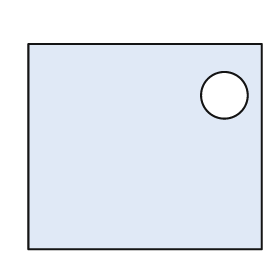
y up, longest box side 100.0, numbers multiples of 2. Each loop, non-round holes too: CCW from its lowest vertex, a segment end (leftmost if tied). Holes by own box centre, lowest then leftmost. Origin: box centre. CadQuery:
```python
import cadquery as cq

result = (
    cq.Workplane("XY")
    .moveTo(-50.0, -44.0)
    .lineTo(50.0, -44.0)
    .lineTo(50.0, 44.0)
    .lineTo(-50.0, 44.0)
    .close()
    .moveTo(34.0, 22.0)
    .circle(10.0)
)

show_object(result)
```